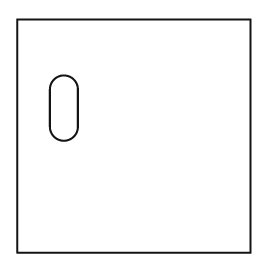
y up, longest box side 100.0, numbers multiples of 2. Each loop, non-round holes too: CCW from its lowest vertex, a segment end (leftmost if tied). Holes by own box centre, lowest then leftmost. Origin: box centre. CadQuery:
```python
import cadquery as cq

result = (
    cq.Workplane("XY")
    .moveTo(-50.0, -50.0)
    .lineTo(50.0, -50.0)
    .lineTo(50.0, 50.0)
    .lineTo(-50.0, 50.0)
    .close()
    .moveTo(-36.0, 4.0)
    .threePointArc((-30.0, -2.0), (-24.0, 4.0))
    .lineTo(-24.0, 20.0)
    .threePointArc((-30.0, 26.0), (-36.0, 20.0))
    .close()
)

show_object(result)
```